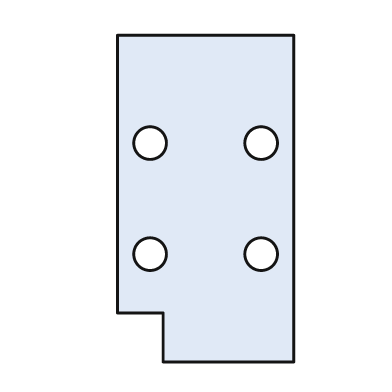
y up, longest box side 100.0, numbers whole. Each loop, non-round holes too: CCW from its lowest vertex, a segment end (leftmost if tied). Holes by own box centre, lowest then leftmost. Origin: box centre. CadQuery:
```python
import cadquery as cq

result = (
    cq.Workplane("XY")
    .moveTo(-13.0, -50.0)
    .lineTo(27.0, -50.0)
    .lineTo(27.0, 50.0)
    .lineTo(-27.0, 50.0)
    .lineTo(-27.0, -35.0)
    .lineTo(-13.0, -35.0)
    .close()
    .moveTo(-17.0, -17.0)
    .circle(5.0)
    .moveTo(17.0, -17.0)
    .circle(5.0)
    .moveTo(-17.0, 17.0)
    .circle(5.0)
    .moveTo(17.0, 17.0)
    .circle(5.0)
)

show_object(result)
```